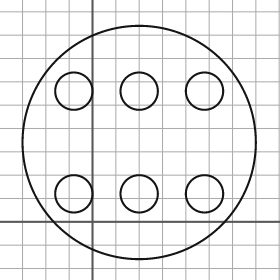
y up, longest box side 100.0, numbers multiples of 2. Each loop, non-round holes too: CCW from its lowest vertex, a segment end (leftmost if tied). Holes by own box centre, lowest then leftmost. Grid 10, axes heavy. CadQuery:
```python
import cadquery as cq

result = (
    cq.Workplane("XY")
    .moveTo(20.0, 34.0)
    .circle(50.0)
    .moveTo(-8.0, 12.0)
    .circle(8.0)
    .moveTo(20.0, 12.0)
    .circle(8.0)
    .moveTo(48.0, 12.0)
    .circle(8.0)
    .moveTo(-8.0, 56.0)
    .circle(8.0)
    .moveTo(20.0, 56.0)
    .circle(8.0)
    .moveTo(48.0, 56.0)
    .circle(8.0)
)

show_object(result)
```